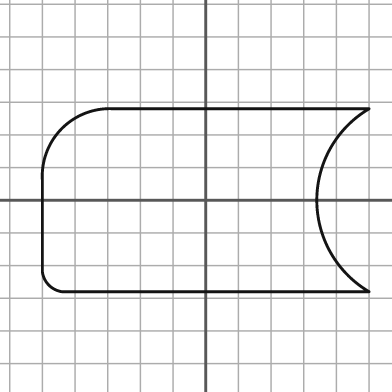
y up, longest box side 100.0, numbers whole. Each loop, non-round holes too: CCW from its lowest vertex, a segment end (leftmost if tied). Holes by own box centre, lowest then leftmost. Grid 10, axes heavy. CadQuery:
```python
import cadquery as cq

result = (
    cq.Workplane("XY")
    .moveTo(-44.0, -28.0)
    .lineTo(50.0, -28.0)
    .threePointArc((34.0, 0.0), (50.0, 28.0))
    .lineTo(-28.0, 28.0)
    .threePointArc((-44.0, 22.0), (-50.0, 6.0))
    .lineTo(-50.0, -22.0)
    .threePointArc((-48.0, -26.0), (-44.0, -28.0))
    .close()
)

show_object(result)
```